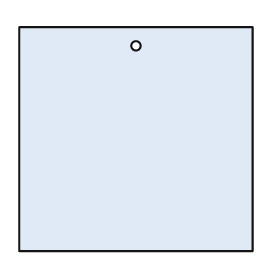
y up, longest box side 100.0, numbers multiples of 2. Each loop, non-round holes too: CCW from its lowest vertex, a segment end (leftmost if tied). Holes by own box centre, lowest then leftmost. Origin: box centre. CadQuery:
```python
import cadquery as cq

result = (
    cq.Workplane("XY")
    .moveTo(-50.0, -48.0)
    .lineTo(50.0, -48.0)
    .lineTo(50.0, 48.0)
    .lineTo(-50.0, 48.0)
    .close()
    .moveTo(0.0, 40.0)
    .circle(2.0)
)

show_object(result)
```